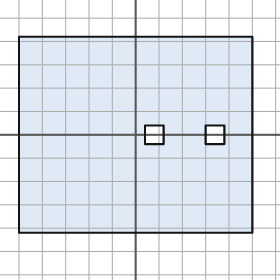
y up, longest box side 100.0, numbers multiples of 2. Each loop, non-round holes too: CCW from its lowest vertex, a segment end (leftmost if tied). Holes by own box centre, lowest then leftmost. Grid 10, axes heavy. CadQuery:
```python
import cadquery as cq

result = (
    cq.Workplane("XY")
    .moveTo(-50.0, -42.0)
    .lineTo(50.0, -42.0)
    .lineTo(50.0, 42.0)
    .lineTo(-50.0, 42.0)
    .close()
    .moveTo(4.0, -4.0)
    .lineTo(12.0, -4.0)
    .lineTo(12.0, 4.0)
    .lineTo(4.0, 4.0)
    .close()
    .moveTo(30.0, -4.0)
    .lineTo(38.0, -4.0)
    .lineTo(38.0, 4.0)
    .lineTo(30.0, 4.0)
    .close()
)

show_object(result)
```